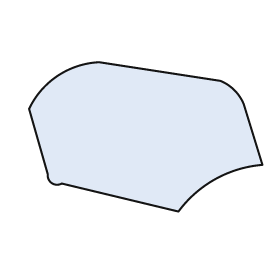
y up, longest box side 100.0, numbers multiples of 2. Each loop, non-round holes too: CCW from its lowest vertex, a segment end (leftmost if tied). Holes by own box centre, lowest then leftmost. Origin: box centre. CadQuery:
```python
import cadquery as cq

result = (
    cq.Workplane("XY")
    .moveTo(14.0, -32.0)
    .threePointArc((30.0, -18.0), (50.0, -12.0))
    .lineTo(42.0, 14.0)
    .threePointArc((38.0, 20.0), (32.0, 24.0))
    .lineTo(-20.0, 32.0)
    .threePointArc((-38.0, 26.0), (-50.0, 12.0))
    .lineTo(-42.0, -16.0)
    .threePointArc((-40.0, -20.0), (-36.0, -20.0))
    .close()
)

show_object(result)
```